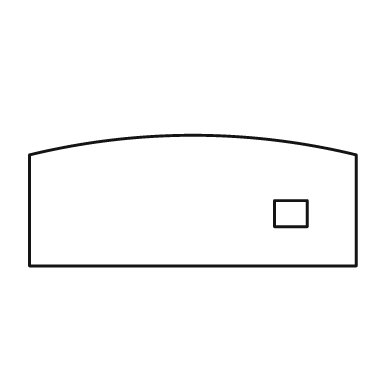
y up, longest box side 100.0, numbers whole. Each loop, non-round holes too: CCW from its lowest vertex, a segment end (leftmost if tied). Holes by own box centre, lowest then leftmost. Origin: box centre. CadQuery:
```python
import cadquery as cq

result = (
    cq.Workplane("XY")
    .moveTo(-50.0, -20.0)
    .lineTo(50.0, -20.0)
    .lineTo(50.0, 14.0)
    .threePointArc((0.0, 20.0), (-50.0, 14.0))
    .close()
    .moveTo(25.0, -8.0)
    .lineTo(35.0, -8.0)
    .lineTo(35.0, 0.0)
    .lineTo(25.0, 0.0)
    .close()
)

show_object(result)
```